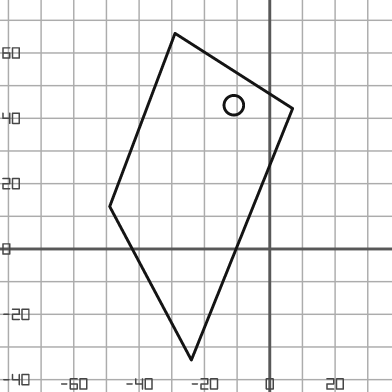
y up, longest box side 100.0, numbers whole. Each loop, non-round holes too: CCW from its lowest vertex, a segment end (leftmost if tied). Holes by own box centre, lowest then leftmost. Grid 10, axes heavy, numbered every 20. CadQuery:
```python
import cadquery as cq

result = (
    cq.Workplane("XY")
    .moveTo(-24.0, -34.0)
    .lineTo(7.0, 43.0)
    .lineTo(-29.0, 66.0)
    .lineTo(-49.0, 13.0)
    .close()
    .moveTo(-11.0, 44.0)
    .circle(3.0)
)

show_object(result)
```